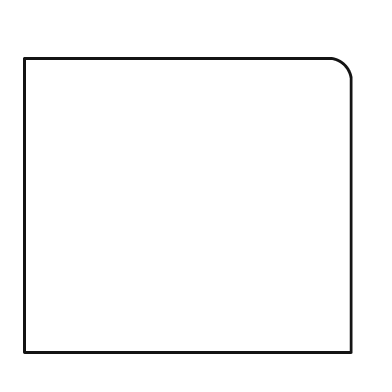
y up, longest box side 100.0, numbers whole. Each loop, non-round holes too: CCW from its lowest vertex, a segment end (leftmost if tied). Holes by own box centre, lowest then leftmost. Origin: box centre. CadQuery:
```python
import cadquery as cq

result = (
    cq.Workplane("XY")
    .moveTo(-50.0, -45.0)
    .lineTo(50.0, -45.0)
    .lineTo(50.0, 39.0)
    .threePointArc((48.0, 43.0), (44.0, 45.0))
    .lineTo(-50.0, 45.0)
    .close()
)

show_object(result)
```